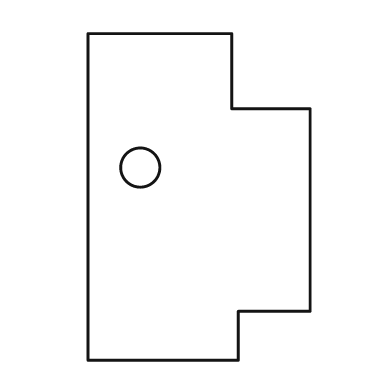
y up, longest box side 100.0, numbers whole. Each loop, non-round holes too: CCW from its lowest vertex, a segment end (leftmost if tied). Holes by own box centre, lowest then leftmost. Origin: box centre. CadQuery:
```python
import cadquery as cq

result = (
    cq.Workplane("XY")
    .moveTo(-34.0, -50.0)
    .lineTo(12.0, -50.0)
    .lineTo(12.0, -35.0)
    .lineTo(34.0, -35.0)
    .lineTo(34.0, 27.0)
    .lineTo(10.0, 27.0)
    .lineTo(10.0, 50.0)
    .lineTo(-34.0, 50.0)
    .close()
    .moveTo(-18.0, 9.0)
    .circle(6.0)
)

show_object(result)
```